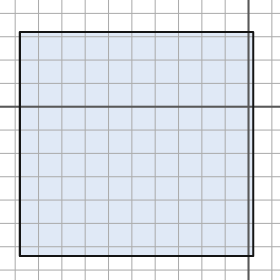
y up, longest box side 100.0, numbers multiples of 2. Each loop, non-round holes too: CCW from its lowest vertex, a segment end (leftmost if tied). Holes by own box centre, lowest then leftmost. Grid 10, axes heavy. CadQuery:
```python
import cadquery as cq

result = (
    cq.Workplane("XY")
    .moveTo(-98.0, -64.0)
    .lineTo(2.0, -64.0)
    .lineTo(2.0, 32.0)
    .lineTo(-98.0, 32.0)
    .close()
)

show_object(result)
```